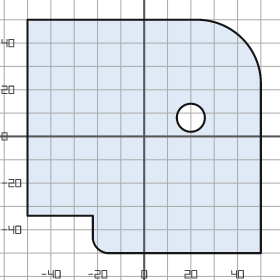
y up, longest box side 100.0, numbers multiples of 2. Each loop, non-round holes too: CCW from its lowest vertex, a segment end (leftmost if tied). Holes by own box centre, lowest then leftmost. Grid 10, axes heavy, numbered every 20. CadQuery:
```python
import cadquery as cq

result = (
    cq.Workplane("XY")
    .moveTo(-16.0, -50.0)
    .lineTo(50.0, -50.0)
    .lineTo(50.0, 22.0)
    .threePointArc((42.0, 42.0), (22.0, 50.0))
    .lineTo(-50.0, 50.0)
    .lineTo(-50.0, -34.0)
    .lineTo(-22.0, -34.0)
    .lineTo(-22.0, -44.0)
    .threePointArc((-20.0, -48.0), (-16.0, -50.0))
    .close()
    .moveTo(20.0, 8.0)
    .circle(6.0)
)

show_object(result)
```